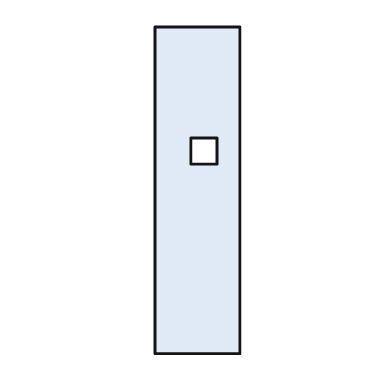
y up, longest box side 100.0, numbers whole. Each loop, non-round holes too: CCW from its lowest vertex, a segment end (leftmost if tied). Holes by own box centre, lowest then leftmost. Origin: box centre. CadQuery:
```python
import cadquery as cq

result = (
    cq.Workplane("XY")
    .moveTo(-13.0, -50.0)
    .lineTo(13.0, -50.0)
    .lineTo(13.0, 50.0)
    .lineTo(-13.0, 50.0)
    .close()
    .moveTo(-2.0, 8.0)
    .lineTo(6.0, 8.0)
    .lineTo(6.0, 16.0)
    .lineTo(-2.0, 16.0)
    .close()
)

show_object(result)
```